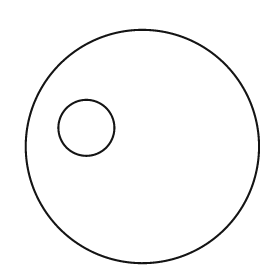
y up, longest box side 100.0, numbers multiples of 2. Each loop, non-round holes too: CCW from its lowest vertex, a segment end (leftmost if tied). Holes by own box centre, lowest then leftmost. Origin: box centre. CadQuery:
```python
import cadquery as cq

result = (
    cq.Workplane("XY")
    .moveTo(0.0, 0.0)
    .circle(50.0)
    .moveTo(-24.0, 8.0)
    .circle(12.0)
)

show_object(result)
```